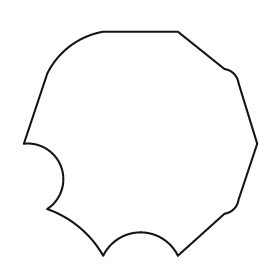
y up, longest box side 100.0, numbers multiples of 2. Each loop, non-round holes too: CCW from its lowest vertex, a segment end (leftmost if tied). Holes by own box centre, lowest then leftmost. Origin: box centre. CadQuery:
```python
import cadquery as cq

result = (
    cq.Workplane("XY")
    .moveTo(-16.0, -48.0)
    .threePointArc((0.0, -38.0), (16.0, -48.0))
    .lineTo(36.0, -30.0)
    .threePointArc((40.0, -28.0), (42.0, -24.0))
    .lineTo(50.0, 0.0)
    .lineTo(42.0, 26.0)
    .threePointArc((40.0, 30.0), (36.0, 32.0))
    .lineTo(16.0, 48.0)
    .lineTo(-16.0, 48.0)
    .threePointArc((-30.0, 42.0), (-40.0, 30.0))
    .lineTo(-50.0, 0.0)
    .threePointArc((-34.0, -10.0), (-40.0, -28.0))
    .threePointArc((-26.0, -36.0), (-16.0, -48.0))
    .close()
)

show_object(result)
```